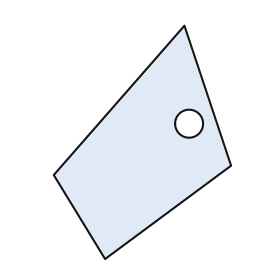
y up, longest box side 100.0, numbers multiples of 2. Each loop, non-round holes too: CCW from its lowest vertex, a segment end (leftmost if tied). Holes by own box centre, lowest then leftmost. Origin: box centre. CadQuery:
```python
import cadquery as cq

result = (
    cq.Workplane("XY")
    .moveTo(-16.0, -50.0)
    .lineTo(38.0, -10.0)
    .lineTo(18.0, 50.0)
    .lineTo(-38.0, -14.0)
    .close()
    .moveTo(20.0, 8.0)
    .circle(6.0)
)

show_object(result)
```